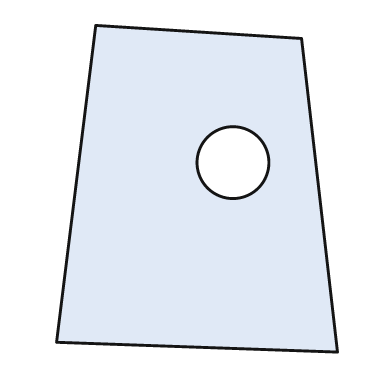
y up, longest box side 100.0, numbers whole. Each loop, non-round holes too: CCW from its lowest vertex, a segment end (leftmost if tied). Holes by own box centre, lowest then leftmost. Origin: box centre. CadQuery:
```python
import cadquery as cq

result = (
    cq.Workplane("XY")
    .moveTo(43.0, -50.0)
    .lineTo(32.0, 46.0)
    .lineTo(-31.0, 50.0)
    .lineTo(-43.0, -47.0)
    .close()
    .moveTo(11.0, 8.0)
    .circle(11.0)
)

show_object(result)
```